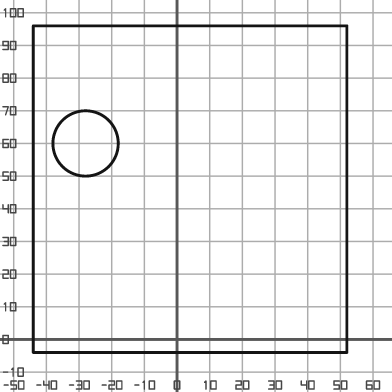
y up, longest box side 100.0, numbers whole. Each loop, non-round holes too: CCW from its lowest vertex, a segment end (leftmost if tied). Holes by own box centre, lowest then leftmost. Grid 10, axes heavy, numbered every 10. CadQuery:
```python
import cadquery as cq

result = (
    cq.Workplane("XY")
    .moveTo(-44.0, -4.0)
    .lineTo(52.0, -4.0)
    .lineTo(52.0, 96.0)
    .lineTo(-44.0, 96.0)
    .close()
    .moveTo(-28.0, 60.0)
    .circle(10.0)
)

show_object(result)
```